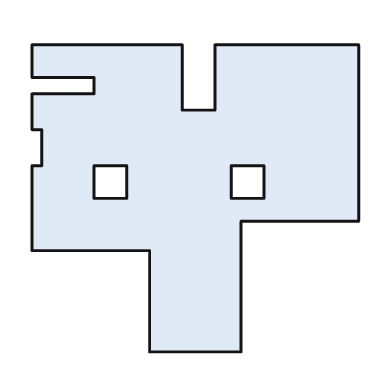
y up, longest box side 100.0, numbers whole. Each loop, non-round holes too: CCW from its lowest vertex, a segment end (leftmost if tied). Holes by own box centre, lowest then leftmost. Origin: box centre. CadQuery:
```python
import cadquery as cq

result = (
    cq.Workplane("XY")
    .moveTo(-14.0, -47.0)
    .lineTo(14.0, -47.0)
    .lineTo(14.0, -7.0)
    .lineTo(50.0, -7.0)
    .lineTo(50.0, 47.0)
    .lineTo(6.0, 47.0)
    .lineTo(6.0, 27.0)
    .lineTo(-4.0, 27.0)
    .lineTo(-4.0, 47.0)
    .lineTo(-50.0, 47.0)
    .lineTo(-50.0, 37.0)
    .lineTo(-31.0, 37.0)
    .lineTo(-31.0, 32.0)
    .lineTo(-50.0, 32.0)
    .lineTo(-50.0, 21.0)
    .lineTo(-47.0, 21.0)
    .lineTo(-47.0, 10.0)
    .lineTo(-50.0, 10.0)
    .lineTo(-50.0, -16.0)
    .lineTo(-14.0, -16.0)
    .close()
    .moveTo(-31.0, 0.0)
    .lineTo(-21.0, 0.0)
    .lineTo(-21.0, 10.0)
    .lineTo(-31.0, 10.0)
    .close()
    .moveTo(11.0, 0.0)
    .lineTo(21.0, 0.0)
    .lineTo(21.0, 10.0)
    .lineTo(11.0, 10.0)
    .close()
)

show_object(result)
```